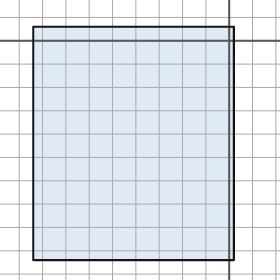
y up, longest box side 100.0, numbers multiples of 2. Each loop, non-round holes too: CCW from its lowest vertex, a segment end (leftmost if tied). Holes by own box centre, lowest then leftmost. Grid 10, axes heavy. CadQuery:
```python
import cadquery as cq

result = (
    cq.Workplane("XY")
    .moveTo(-84.0, -94.0)
    .lineTo(2.0, -94.0)
    .lineTo(2.0, 6.0)
    .lineTo(-84.0, 6.0)
    .close()
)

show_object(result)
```